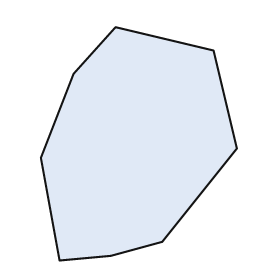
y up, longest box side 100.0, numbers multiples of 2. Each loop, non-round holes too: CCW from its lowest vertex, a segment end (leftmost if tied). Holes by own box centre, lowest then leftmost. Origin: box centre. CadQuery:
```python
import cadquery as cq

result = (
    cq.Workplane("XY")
    .moveTo(-34.0, -50.0)
    .lineTo(-12.0, -48.0)
    .lineTo(10.0, -42.0)
    .lineTo(42.0, -2.0)
    .lineTo(32.0, 40.0)
    .lineTo(-10.0, 50.0)
    .lineTo(-28.0, 30.0)
    .lineTo(-42.0, -6.0)
    .close()
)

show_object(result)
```